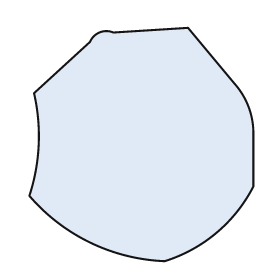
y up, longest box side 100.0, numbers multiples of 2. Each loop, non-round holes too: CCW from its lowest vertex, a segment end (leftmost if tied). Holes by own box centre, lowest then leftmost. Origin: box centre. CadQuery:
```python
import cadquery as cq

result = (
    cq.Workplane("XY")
    .moveTo(10.0, -50.0)
    .threePointArc((32.0, -38.0), (48.0, -18.0))
    .lineTo(48.0, 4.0)
    .threePointArc((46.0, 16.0), (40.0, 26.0))
    .lineTo(20.0, 50.0)
    .lineTo(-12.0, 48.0)
    .threePointArc((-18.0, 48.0), (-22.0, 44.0))
    .lineTo(-46.0, 22.0)
    .threePointArc((-44.0, 0.0), (-48.0, -22.0))
    .threePointArc((-22.0, -42.0), (10.0, -50.0))
    .close()
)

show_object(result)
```